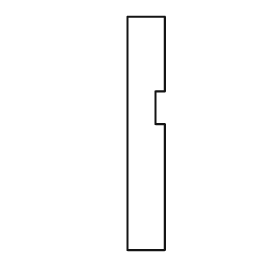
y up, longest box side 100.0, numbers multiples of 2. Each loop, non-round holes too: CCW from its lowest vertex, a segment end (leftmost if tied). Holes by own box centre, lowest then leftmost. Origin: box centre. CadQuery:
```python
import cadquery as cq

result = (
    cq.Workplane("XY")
    .moveTo(-8.0, -50.0)
    .lineTo(8.0, -50.0)
    .lineTo(8.0, 4.0)
    .lineTo(4.0, 4.0)
    .lineTo(4.0, 18.0)
    .lineTo(8.0, 18.0)
    .lineTo(8.0, 50.0)
    .lineTo(-8.0, 50.0)
    .close()
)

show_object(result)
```